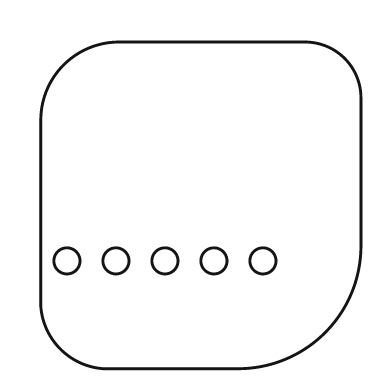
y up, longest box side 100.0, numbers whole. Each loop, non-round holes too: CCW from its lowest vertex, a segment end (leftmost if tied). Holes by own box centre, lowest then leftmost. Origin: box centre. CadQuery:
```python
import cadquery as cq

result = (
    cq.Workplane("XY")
    .moveTo(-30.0, -50.0)
    .lineTo(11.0, -50.0)
    .threePointArc((38.0, -39.0), (49.0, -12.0))
    .lineTo(49.0, 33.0)
    .threePointArc((44.0, 45.0), (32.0, 50.0))
    .lineTo(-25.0, 50.0)
    .threePointArc((-42.0, 43.0), (-49.0, 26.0))
    .lineTo(-49.0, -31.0)
    .threePointArc((-43.0, -44.0), (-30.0, -50.0))
    .close()
    .moveTo(-41.0, -17.0)
    .circle(4.0)
    .moveTo(-26.0, -17.0)
    .circle(4.0)
    .moveTo(-11.0, -17.0)
    .circle(4.0)
    .moveTo(4.0, -17.0)
    .circle(4.0)
    .moveTo(19.0, -17.0)
    .circle(4.0)
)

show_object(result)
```